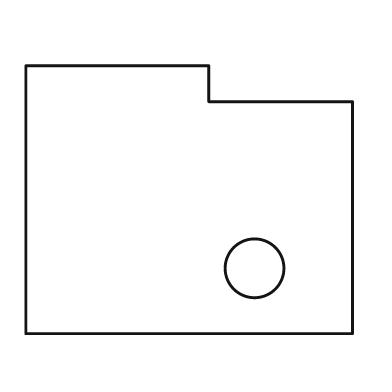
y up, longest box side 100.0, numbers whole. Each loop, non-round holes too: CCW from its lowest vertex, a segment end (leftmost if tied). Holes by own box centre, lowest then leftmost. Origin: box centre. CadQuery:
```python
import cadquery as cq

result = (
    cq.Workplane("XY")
    .moveTo(-50.0, -41.0)
    .lineTo(50.0, -41.0)
    .lineTo(50.0, 30.0)
    .lineTo(6.0, 30.0)
    .lineTo(6.0, 41.0)
    .lineTo(-50.0, 41.0)
    .close()
    .moveTo(20.0, -21.0)
    .circle(9.0)
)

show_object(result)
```